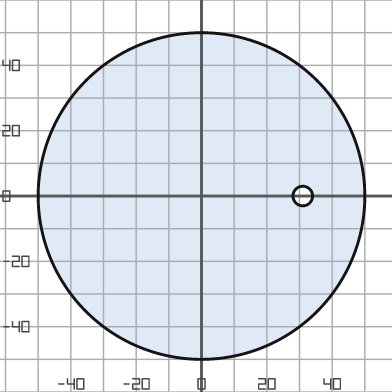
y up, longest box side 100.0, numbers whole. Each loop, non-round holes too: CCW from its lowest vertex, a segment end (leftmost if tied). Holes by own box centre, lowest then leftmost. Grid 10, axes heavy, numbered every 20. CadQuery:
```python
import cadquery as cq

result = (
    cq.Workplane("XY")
    .moveTo(0.0, 0.0)
    .circle(50.0)
    .moveTo(31.0, 0.0)
    .circle(3.0)
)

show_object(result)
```